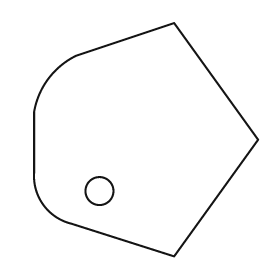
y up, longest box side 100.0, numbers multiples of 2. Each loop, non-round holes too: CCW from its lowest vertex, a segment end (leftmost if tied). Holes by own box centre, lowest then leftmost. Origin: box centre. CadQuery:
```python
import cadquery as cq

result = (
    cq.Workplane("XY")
    .moveTo(12.0, -50.0)
    .lineTo(48.0, 0.0)
    .lineTo(12.0, 50.0)
    .lineTo(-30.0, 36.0)
    .threePointArc((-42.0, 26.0), (-48.0, 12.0))
    .lineTo(-48.0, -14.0)
    .threePointArc((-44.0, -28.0), (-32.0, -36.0))
    .close()
    .moveTo(-20.0, -22.0)
    .circle(6.0)
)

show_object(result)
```